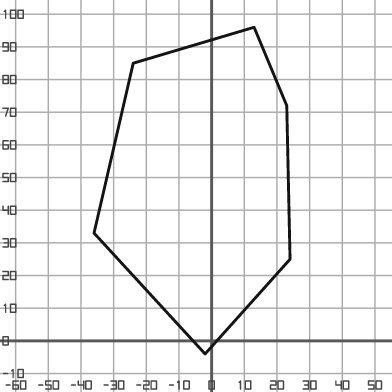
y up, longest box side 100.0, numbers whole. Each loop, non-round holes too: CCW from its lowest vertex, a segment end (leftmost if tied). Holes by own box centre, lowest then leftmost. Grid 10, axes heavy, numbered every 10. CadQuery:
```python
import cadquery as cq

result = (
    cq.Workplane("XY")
    .moveTo(-2.0, -4.0)
    .lineTo(24.0, 25.0)
    .lineTo(23.0, 72.0)
    .lineTo(13.0, 96.0)
    .lineTo(-24.0, 85.0)
    .lineTo(-36.0, 33.0)
    .close()
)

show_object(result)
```